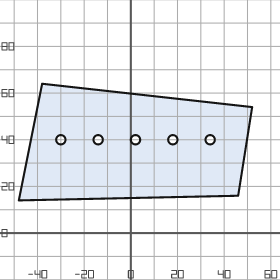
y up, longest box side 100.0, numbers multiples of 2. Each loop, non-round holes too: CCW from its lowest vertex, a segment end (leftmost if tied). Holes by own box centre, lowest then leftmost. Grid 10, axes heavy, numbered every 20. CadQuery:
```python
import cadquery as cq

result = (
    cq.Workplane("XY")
    .moveTo(-48.0, 14.0)
    .lineTo(46.0, 16.0)
    .lineTo(52.0, 54.0)
    .lineTo(-38.0, 64.0)
    .close()
    .moveTo(-30.0, 40.0)
    .circle(2.0)
    .moveTo(-14.0, 40.0)
    .circle(2.0)
    .moveTo(2.0, 40.0)
    .circle(2.0)
    .moveTo(18.0, 40.0)
    .circle(2.0)
    .moveTo(34.0, 40.0)
    .circle(2.0)
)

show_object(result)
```